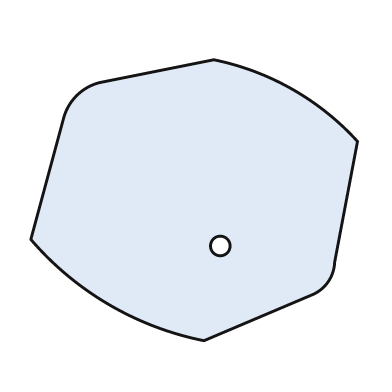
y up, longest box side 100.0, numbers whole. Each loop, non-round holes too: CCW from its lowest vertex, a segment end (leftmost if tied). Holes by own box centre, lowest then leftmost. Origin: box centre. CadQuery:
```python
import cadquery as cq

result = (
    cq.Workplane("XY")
    .moveTo(3.0, -43.0)
    .lineTo(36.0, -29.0)
    .threePointArc((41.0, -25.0), (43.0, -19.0))
    .lineTo(50.0, 18.0)
    .threePointArc((30.0, 34.0), (6.0, 43.0))
    .lineTo(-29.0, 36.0)
    .threePointArc((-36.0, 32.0), (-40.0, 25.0))
    .lineTo(-50.0, -12.0)
    .threePointArc((-26.0, -32.0), (3.0, -43.0))
    .close()
    .moveTo(8.0, -14.0)
    .circle(3.0)
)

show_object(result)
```